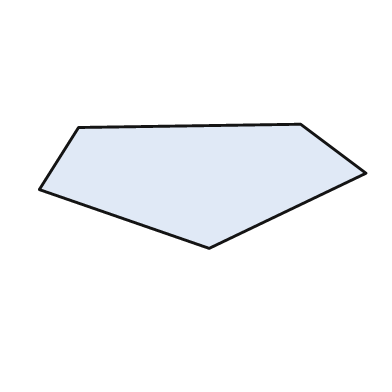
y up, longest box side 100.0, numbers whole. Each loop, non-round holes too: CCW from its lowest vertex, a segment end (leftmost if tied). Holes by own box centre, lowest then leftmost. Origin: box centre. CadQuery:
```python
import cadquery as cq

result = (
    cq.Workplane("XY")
    .moveTo(2.0, -19.0)
    .lineTo(50.0, 4.0)
    .lineTo(30.0, 19.0)
    .lineTo(-38.0, 18.0)
    .lineTo(-50.0, -1.0)
    .close()
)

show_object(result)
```